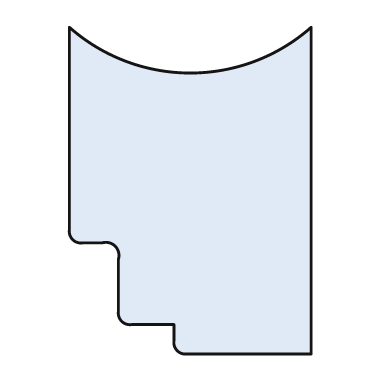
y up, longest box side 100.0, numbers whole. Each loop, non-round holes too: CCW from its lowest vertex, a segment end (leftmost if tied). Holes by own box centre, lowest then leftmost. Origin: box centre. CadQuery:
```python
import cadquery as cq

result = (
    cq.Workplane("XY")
    .moveTo(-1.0, -50.0)
    .lineTo(37.0, -50.0)
    .lineTo(37.0, 50.0)
    .threePointArc((0.0, 36.0), (-37.0, 50.0))
    .lineTo(-37.0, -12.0)
    .threePointArc((-36.0, -15.0), (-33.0, -16.0))
    .lineTo(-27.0, -16.0)
    .threePointArc((-23.0, -17.0), (-22.0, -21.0))
    .lineTo(-22.0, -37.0)
    .threePointArc((-21.0, -40.0), (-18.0, -41.0))
    .lineTo(-5.0, -41.0)
    .lineTo(-5.0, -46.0)
    .threePointArc((-4.0, -49.0), (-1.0, -50.0))
    .close()
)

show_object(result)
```